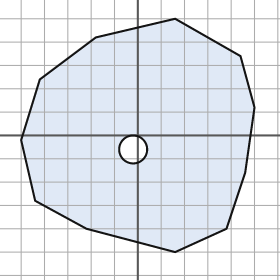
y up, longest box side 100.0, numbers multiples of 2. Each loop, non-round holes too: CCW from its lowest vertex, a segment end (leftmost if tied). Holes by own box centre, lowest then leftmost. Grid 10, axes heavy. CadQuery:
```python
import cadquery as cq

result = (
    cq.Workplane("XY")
    .moveTo(16.0, -50.0)
    .lineTo(38.0, -40.0)
    .lineTo(46.0, -16.0)
    .lineTo(50.0, 12.0)
    .lineTo(44.0, 34.0)
    .lineTo(16.0, 50.0)
    .lineTo(-18.0, 42.0)
    .lineTo(-42.0, 24.0)
    .lineTo(-50.0, -2.0)
    .lineTo(-44.0, -28.0)
    .lineTo(-22.0, -40.0)
    .close()
    .moveTo(-2.0, -6.0)
    .circle(6.0)
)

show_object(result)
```